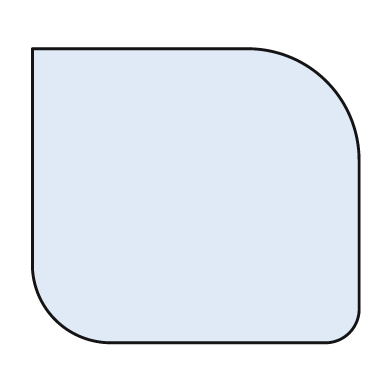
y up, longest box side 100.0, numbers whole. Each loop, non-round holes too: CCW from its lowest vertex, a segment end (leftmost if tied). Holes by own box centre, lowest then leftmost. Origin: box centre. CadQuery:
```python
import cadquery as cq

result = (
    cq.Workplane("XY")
    .moveTo(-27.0, -45.0)
    .lineTo(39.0, -45.0)
    .threePointArc((47.0, -42.0), (50.0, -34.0))
    .lineTo(50.0, 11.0)
    .threePointArc((40.0, 35.0), (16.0, 45.0))
    .lineTo(-50.0, 45.0)
    .lineTo(-50.0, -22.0)
    .threePointArc((-43.0, -38.0), (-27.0, -45.0))
    .close()
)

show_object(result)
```